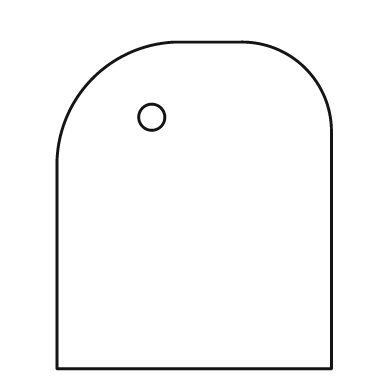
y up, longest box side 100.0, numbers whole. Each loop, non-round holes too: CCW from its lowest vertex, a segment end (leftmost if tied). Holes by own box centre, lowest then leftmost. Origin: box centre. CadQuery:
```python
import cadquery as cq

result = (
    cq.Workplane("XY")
    .moveTo(-42.0, -50.0)
    .lineTo(42.0, -50.0)
    .lineTo(42.0, 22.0)
    .threePointArc((34.0, 42.0), (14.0, 50.0))
    .lineTo(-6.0, 50.0)
    .threePointArc((-31.0, 39.0), (-42.0, 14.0))
    .close()
    .moveTo(-13.0, 27.0)
    .circle(4.0)
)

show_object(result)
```